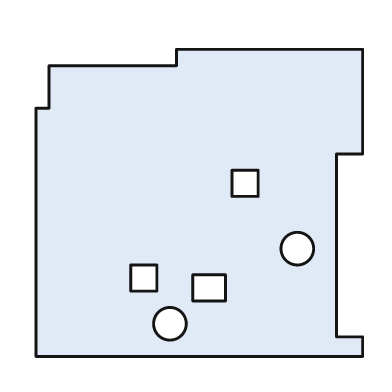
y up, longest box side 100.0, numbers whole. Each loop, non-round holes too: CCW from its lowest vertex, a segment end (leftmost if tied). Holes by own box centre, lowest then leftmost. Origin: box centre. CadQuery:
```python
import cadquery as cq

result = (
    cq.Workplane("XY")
    .moveTo(-50.0, -47.0)
    .lineTo(50.0, -47.0)
    .lineTo(50.0, -41.0)
    .lineTo(42.0, -41.0)
    .lineTo(42.0, 15.0)
    .lineTo(50.0, 15.0)
    .lineTo(50.0, 47.0)
    .lineTo(-7.0, 47.0)
    .lineTo(-7.0, 42.0)
    .lineTo(-46.0, 42.0)
    .lineTo(-46.0, 29.0)
    .lineTo(-50.0, 29.0)
    .close()
    .moveTo(-9.0, -37.0)
    .circle(5.0)
    .moveTo(-2.0, -30.0)
    .lineTo(8.0, -30.0)
    .lineTo(8.0, -22.0)
    .lineTo(-2.0, -22.0)
    .close()
    .moveTo(-21.0, -27.0)
    .lineTo(-13.0, -27.0)
    .lineTo(-13.0, -19.0)
    .lineTo(-21.0, -19.0)
    .close()
    .moveTo(30.0, -14.0)
    .circle(5.0)
    .moveTo(10.0, 2.0)
    .lineTo(18.0, 2.0)
    .lineTo(18.0, 10.0)
    .lineTo(10.0, 10.0)
    .close()
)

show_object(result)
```